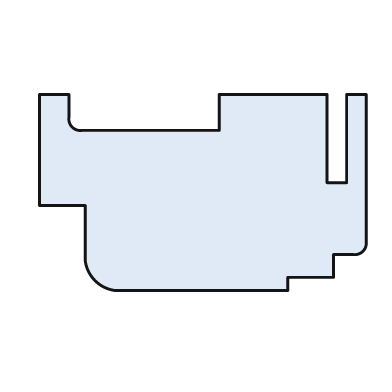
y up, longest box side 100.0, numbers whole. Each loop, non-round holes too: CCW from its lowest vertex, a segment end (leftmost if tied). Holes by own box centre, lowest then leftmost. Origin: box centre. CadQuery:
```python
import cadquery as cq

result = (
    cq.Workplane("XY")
    .moveTo(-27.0, -30.0)
    .lineTo(26.0, -30.0)
    .lineTo(26.0, -26.0)
    .lineTo(40.0, -26.0)
    .lineTo(40.0, -19.0)
    .lineTo(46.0, -19.0)
    .threePointArc((49.0, -18.0), (50.0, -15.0))
    .lineTo(50.0, 30.0)
    .lineTo(44.0, 30.0)
    .lineTo(44.0, 3.0)
    .lineTo(38.0, 3.0)
    .lineTo(38.0, 30.0)
    .lineTo(5.0, 30.0)
    .lineTo(5.0, 19.0)
    .lineTo(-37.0, 19.0)
    .threePointArc((-40.0, 20.0), (-41.0, 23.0))
    .lineTo(-41.0, 30.0)
    .lineTo(-50.0, 30.0)
    .lineTo(-50.0, -4.0)
    .lineTo(-36.0, -4.0)
    .lineTo(-36.0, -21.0)
    .threePointArc((-33.0, -27.0), (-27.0, -30.0))
    .close()
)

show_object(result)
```